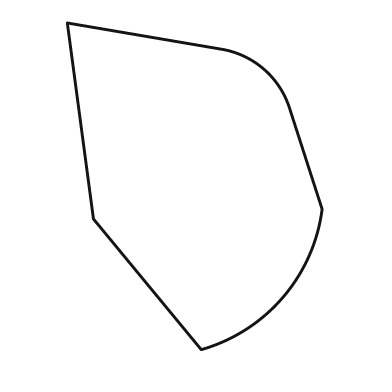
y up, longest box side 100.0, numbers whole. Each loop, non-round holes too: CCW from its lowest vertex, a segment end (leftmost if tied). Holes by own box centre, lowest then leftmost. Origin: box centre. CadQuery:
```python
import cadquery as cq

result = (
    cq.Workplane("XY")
    .moveTo(2.0, -50.0)
    .threePointArc((27.0, -34.0), (39.0, -7.0))
    .lineTo(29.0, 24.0)
    .threePointArc((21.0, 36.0), (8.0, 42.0))
    .lineTo(-39.0, 50.0)
    .lineTo(-31.0, -10.0)
    .close()
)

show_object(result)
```